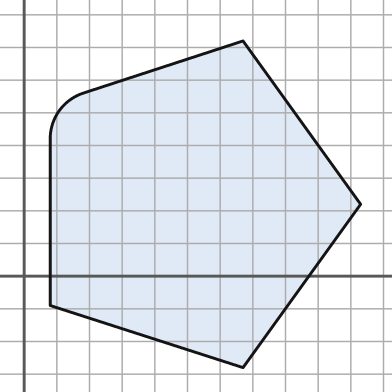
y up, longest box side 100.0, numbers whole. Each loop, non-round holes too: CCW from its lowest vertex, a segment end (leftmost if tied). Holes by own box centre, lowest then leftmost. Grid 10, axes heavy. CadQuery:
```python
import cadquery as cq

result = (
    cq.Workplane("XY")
    .moveTo(67.0, -28.0)
    .lineTo(103.0, 22.0)
    .lineTo(67.0, 72.0)
    .lineTo(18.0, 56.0)
    .threePointArc((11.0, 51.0), (8.0, 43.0))
    .lineTo(8.0, -9.0)
    .close()
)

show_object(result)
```